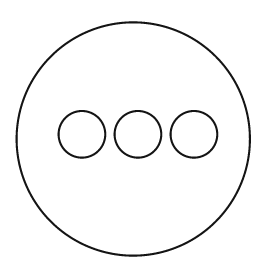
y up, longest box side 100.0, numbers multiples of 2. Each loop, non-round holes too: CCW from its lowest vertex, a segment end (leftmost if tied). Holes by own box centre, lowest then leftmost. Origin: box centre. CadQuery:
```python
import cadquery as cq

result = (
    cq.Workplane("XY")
    .moveTo(0.0, 0.0)
    .circle(50.0)
    .moveTo(-22.0, 2.0)
    .circle(10.0)
    .moveTo(2.0, 2.0)
    .circle(10.0)
    .moveTo(26.0, 2.0)
    .circle(10.0)
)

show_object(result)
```